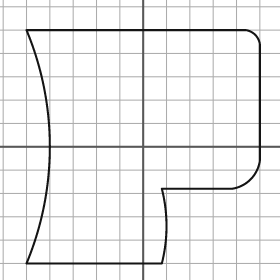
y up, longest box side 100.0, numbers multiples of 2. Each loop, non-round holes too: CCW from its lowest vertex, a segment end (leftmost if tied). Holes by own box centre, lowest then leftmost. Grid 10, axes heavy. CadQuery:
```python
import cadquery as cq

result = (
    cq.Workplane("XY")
    .moveTo(-50.0, -50.0)
    .lineTo(8.0, -50.0)
    .threePointArc((10.0, -34.0), (8.0, -18.0))
    .lineTo(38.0, -18.0)
    .threePointArc((46.0, -14.0), (50.0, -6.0))
    .lineTo(50.0, 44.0)
    .threePointArc((48.0, 48.0), (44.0, 50.0))
    .lineTo(-50.0, 50.0)
    .threePointArc((-40.0, 0.0), (-50.0, -50.0))
    .close()
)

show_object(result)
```